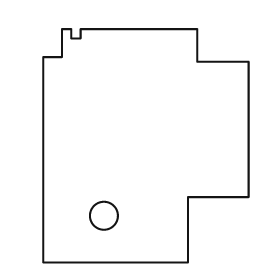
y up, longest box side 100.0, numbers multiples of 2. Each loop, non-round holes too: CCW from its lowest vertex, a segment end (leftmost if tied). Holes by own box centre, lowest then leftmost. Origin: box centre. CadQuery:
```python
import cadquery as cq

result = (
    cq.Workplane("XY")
    .moveTo(-44.0, -50.0)
    .lineTo(18.0, -50.0)
    .lineTo(18.0, -22.0)
    .lineTo(44.0, -22.0)
    .lineTo(44.0, 36.0)
    .lineTo(22.0, 36.0)
    .lineTo(22.0, 50.0)
    .lineTo(-28.0, 50.0)
    .lineTo(-28.0, 46.0)
    .lineTo(-32.0, 46.0)
    .lineTo(-32.0, 50.0)
    .lineTo(-36.0, 50.0)
    .lineTo(-36.0, 38.0)
    .lineTo(-44.0, 38.0)
    .close()
    .moveTo(-18.0, -30.0)
    .circle(6.0)
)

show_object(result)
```